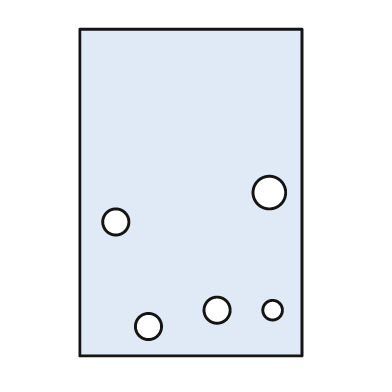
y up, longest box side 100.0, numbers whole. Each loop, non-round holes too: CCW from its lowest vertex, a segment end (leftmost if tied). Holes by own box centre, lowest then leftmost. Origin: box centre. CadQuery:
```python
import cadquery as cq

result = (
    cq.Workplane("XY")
    .moveTo(-34.0, -50.0)
    .lineTo(34.0, -50.0)
    .lineTo(34.0, 50.0)
    .lineTo(-34.0, 50.0)
    .close()
    .moveTo(-13.0, -41.0)
    .circle(4.0)
    .moveTo(8.0, -36.0)
    .circle(4.0)
    .moveTo(25.0, -36.0)
    .circle(3.0)
    .moveTo(-23.0, -9.0)
    .circle(4.0)
    .moveTo(24.0, 0.0)
    .circle(5.0)
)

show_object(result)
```